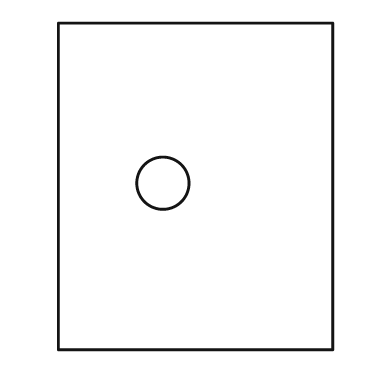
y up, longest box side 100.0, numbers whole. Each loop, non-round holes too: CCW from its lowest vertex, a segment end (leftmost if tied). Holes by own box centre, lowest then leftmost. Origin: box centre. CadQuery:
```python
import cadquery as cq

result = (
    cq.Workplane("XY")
    .moveTo(-42.0, -50.0)
    .lineTo(42.0, -50.0)
    .lineTo(42.0, 50.0)
    .lineTo(-42.0, 50.0)
    .close()
    .moveTo(-10.0, 1.0)
    .circle(8.0)
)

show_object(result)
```